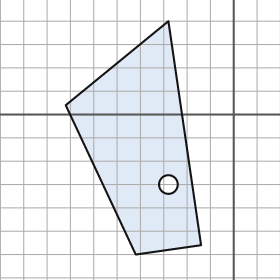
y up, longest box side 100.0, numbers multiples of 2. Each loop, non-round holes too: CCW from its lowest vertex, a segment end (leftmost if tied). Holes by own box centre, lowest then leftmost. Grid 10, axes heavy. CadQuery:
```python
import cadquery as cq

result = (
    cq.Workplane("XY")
    .moveTo(-42.0, -60.0)
    .lineTo(-14.0, -56.0)
    .lineTo(-28.0, 40.0)
    .lineTo(-72.0, 4.0)
    .close()
    .moveTo(-28.0, -30.0)
    .circle(4.0)
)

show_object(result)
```